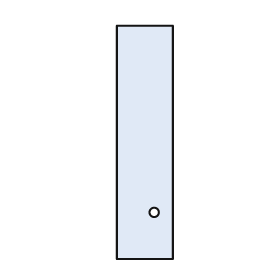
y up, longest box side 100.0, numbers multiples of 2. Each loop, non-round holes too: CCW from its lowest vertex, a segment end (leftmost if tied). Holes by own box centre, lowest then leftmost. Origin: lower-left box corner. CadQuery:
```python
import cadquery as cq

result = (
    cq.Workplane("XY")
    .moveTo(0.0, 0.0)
    .lineTo(24.0, 0.0)
    .lineTo(24.0, 100.0)
    .lineTo(0.0, 100.0)
    .close()
    .moveTo(16.0, 20.0)
    .circle(2.0)
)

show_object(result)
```